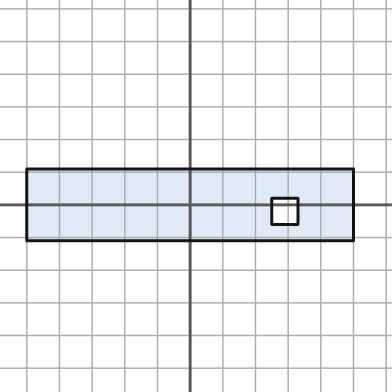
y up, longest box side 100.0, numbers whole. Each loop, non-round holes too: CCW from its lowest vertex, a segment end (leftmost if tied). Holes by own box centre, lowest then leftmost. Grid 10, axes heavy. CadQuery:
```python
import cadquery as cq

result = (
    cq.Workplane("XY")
    .moveTo(-50.0, -11.0)
    .lineTo(50.0, -11.0)
    .lineTo(50.0, 11.0)
    .lineTo(-50.0, 11.0)
    .close()
    .moveTo(25.0, -6.0)
    .lineTo(33.0, -6.0)
    .lineTo(33.0, 2.0)
    .lineTo(25.0, 2.0)
    .close()
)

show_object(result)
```